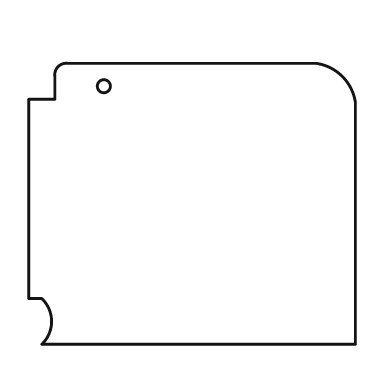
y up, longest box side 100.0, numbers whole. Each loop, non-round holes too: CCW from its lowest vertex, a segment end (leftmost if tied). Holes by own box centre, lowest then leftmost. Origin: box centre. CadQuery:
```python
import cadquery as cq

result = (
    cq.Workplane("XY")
    .moveTo(-46.0, -43.0)
    .lineTo(50.0, -43.0)
    .lineTo(50.0, 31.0)
    .threePointArc((46.0, 39.0), (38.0, 43.0))
    .lineTo(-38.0, 43.0)
    .threePointArc((-41.0, 42.0), (-42.0, 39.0))
    .lineTo(-42.0, 32.0)
    .lineTo(-50.0, 32.0)
    .lineTo(-50.0, -29.0)
    .lineTo(-46.0, -29.0)
    .threePointArc((-43.0, -36.0), (-46.0, -43.0))
    .close()
    .moveTo(-27.0, 36.0)
    .circle(2.0)
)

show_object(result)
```